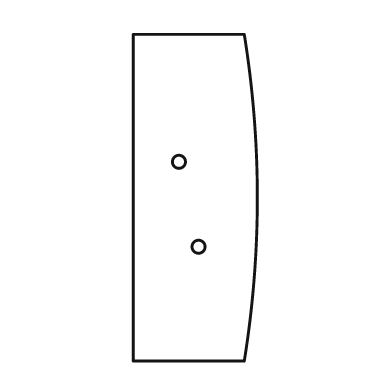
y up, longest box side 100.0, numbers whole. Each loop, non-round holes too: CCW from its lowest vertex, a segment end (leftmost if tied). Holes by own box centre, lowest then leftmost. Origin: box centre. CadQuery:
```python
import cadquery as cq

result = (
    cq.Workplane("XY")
    .moveTo(-19.0, -50.0)
    .lineTo(15.0, -50.0)
    .threePointArc((19.0, 0.0), (15.0, 50.0))
    .lineTo(-19.0, 50.0)
    .close()
    .moveTo(1.0, -15.0)
    .circle(2.0)
    .moveTo(-5.0, 11.0)
    .circle(2.0)
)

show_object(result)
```